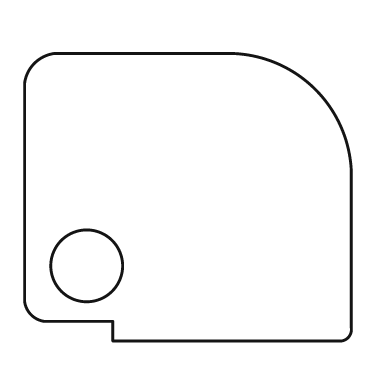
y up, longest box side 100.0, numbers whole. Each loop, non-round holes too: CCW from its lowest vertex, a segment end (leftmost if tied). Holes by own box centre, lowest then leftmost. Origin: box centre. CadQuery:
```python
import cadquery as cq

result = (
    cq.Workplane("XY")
    .moveTo(-23.0, -44.0)
    .lineTo(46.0, -44.0)
    .threePointArc((49.0, -43.0), (50.0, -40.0))
    .lineTo(50.0, 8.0)
    .threePointArc((39.0, 33.0), (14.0, 44.0))
    .lineTo(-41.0, 44.0)
    .threePointArc((-47.0, 41.0), (-50.0, 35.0))
    .lineTo(-50.0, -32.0)
    .threePointArc((-48.0, -36.0), (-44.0, -38.0))
    .lineTo(-23.0, -38.0)
    .close()
    .moveTo(-31.0, -21.0)
    .circle(11.0)
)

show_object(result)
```